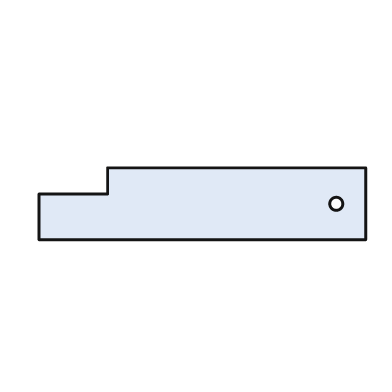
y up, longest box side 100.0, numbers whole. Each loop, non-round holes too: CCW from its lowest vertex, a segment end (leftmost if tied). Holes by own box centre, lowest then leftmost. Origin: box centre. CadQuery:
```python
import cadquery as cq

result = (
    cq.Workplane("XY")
    .moveTo(-50.0, -11.0)
    .lineTo(50.0, -11.0)
    .lineTo(50.0, 11.0)
    .lineTo(-29.0, 11.0)
    .lineTo(-29.0, 3.0)
    .lineTo(-50.0, 3.0)
    .close()
    .moveTo(41.0, 0.0)
    .circle(2.0)
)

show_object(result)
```